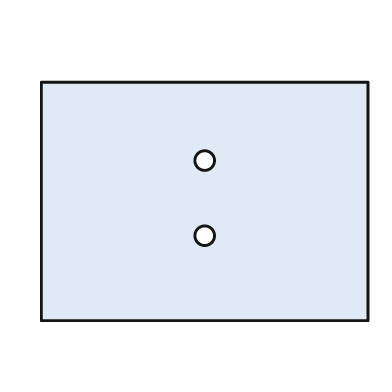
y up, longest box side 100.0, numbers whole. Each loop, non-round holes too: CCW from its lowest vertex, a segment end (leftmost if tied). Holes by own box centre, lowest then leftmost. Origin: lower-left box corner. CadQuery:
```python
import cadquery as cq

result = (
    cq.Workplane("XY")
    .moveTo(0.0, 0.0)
    .lineTo(100.0, 0.0)
    .lineTo(100.0, 73.0)
    .lineTo(0.0, 73.0)
    .close()
    .moveTo(50.0, 26.0)
    .circle(3.0)
    .moveTo(50.0, 49.0)
    .circle(3.0)
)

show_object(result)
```